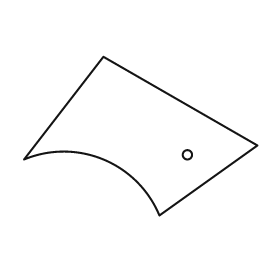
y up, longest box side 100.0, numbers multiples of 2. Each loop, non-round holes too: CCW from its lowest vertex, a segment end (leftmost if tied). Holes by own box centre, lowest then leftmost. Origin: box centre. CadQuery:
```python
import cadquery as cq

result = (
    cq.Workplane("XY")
    .moveTo(8.0, -34.0)
    .lineTo(50.0, -4.0)
    .lineTo(-16.0, 34.0)
    .lineTo(-50.0, -10.0)
    .threePointArc((-16.0, -10.0), (8.0, -34.0))
    .close()
    .moveTo(20.0, -8.0)
    .circle(2.0)
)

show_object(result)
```